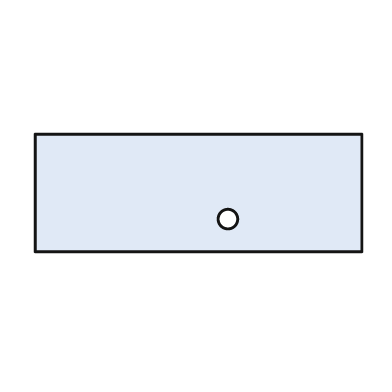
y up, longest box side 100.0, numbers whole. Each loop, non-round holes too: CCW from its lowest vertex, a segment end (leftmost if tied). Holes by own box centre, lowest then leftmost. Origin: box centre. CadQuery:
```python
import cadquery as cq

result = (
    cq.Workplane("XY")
    .moveTo(-50.0, -18.0)
    .lineTo(50.0, -18.0)
    .lineTo(50.0, 18.0)
    .lineTo(-50.0, 18.0)
    .close()
    .moveTo(9.0, -8.0)
    .circle(3.0)
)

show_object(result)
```